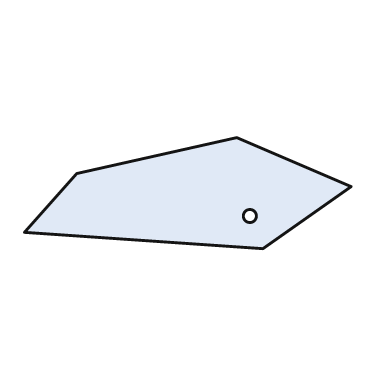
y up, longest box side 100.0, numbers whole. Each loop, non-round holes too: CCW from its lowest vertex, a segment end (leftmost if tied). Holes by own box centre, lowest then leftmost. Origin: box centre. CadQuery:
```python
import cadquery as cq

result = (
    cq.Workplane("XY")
    .moveTo(23.0, -17.0)
    .lineTo(50.0, 2.0)
    .lineTo(15.0, 17.0)
    .lineTo(-34.0, 6.0)
    .lineTo(-50.0, -12.0)
    .close()
    .moveTo(19.0, -7.0)
    .circle(2.0)
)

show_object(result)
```